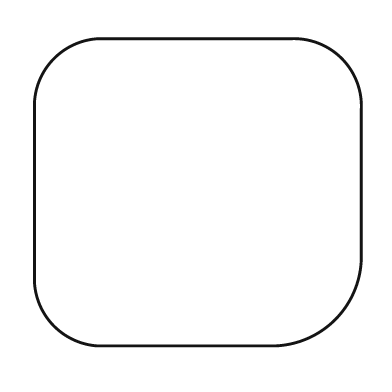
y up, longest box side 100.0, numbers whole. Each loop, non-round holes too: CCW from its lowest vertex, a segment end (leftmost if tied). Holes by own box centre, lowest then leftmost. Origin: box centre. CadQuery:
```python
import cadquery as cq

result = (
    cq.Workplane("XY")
    .moveTo(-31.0, -47.0)
    .lineTo(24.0, -47.0)
    .threePointArc((42.0, -39.0), (50.0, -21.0))
    .lineTo(50.0, 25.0)
    .threePointArc((44.0, 41.0), (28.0, 47.0))
    .lineTo(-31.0, 47.0)
    .threePointArc((-44.0, 41.0), (-50.0, 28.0))
    .lineTo(-50.0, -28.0)
    .threePointArc((-44.0, -41.0), (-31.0, -47.0))
    .close()
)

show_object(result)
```